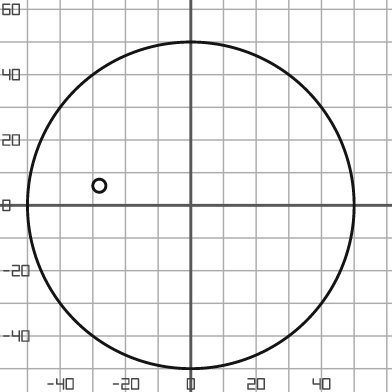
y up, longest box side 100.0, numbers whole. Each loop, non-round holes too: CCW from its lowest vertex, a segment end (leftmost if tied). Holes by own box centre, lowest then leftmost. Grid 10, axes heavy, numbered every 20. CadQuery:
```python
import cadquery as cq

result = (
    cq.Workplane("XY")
    .moveTo(0.0, 0.0)
    .circle(50.0)
    .moveTo(-28.0, 6.0)
    .circle(2.0)
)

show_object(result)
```